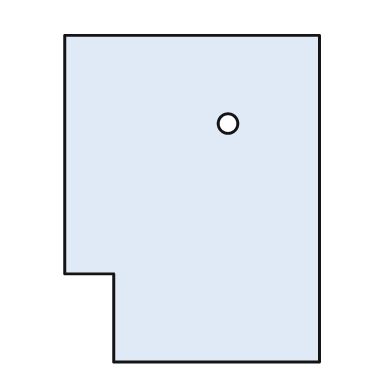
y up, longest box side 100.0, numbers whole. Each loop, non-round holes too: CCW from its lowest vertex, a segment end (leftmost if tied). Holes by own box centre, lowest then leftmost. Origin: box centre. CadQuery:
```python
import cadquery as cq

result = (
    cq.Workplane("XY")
    .moveTo(-24.0, -50.0)
    .lineTo(39.0, -50.0)
    .lineTo(39.0, 50.0)
    .lineTo(-39.0, 50.0)
    .lineTo(-39.0, -23.0)
    .lineTo(-24.0, -23.0)
    .close()
    .moveTo(11.0, 23.0)
    .circle(3.0)
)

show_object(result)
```